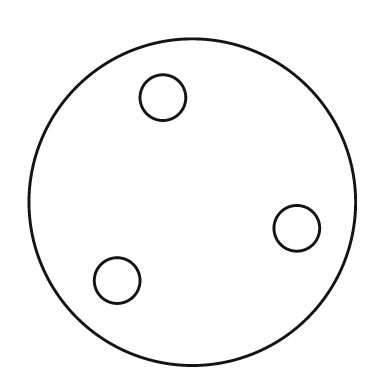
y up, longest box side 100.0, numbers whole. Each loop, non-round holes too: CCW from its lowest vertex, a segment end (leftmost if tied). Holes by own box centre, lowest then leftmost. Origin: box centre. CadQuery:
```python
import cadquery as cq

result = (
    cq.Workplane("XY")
    .moveTo(0.0, 0.0)
    .circle(50.0)
    .moveTo(-23.0, -24.0)
    .circle(7.0)
    .moveTo(32.0, -8.0)
    .circle(7.0)
    .moveTo(-9.0, 32.0)
    .circle(7.0)
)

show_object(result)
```